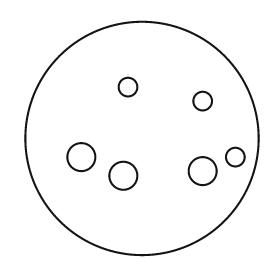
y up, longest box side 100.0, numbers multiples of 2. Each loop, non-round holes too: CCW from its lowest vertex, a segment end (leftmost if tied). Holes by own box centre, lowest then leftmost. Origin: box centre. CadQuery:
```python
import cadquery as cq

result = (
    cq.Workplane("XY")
    .moveTo(0.0, 0.0)
    .circle(50.0)
    .moveTo(-8.0, -16.0)
    .circle(6.0)
    .moveTo(26.0, -14.0)
    .circle(6.0)
    .moveTo(-26.0, -8.0)
    .circle(6.0)
    .moveTo(40.0, -8.0)
    .circle(4.0)
    .moveTo(26.0, 16.0)
    .circle(4.0)
    .moveTo(-6.0, 22.0)
    .circle(4.0)
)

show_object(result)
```